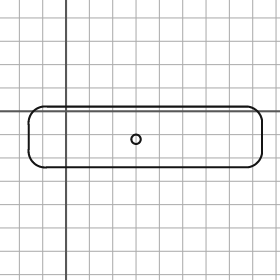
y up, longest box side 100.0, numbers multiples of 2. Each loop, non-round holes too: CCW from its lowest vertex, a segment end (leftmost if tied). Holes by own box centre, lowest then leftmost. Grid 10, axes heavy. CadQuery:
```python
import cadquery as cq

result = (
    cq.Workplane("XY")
    .moveTo(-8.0, -24.0)
    .lineTo(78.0, -24.0)
    .threePointArc((82.0, -22.0), (84.0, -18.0))
    .lineTo(84.0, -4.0)
    .threePointArc((82.0, 0.0), (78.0, 2.0))
    .lineTo(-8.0, 2.0)
    .threePointArc((-14.0, 0.0), (-16.0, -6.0))
    .lineTo(-16.0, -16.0)
    .threePointArc((-14.0, -22.0), (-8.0, -24.0))
    .close()
    .moveTo(30.0, -12.0)
    .circle(2.0)
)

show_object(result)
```